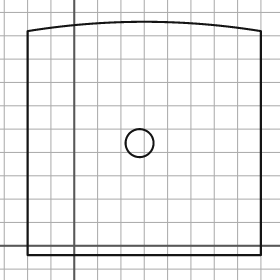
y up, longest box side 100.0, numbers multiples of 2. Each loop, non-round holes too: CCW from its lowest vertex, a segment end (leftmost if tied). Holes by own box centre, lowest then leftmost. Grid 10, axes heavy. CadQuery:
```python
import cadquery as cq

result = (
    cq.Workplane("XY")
    .moveTo(-20.0, -4.0)
    .lineTo(80.0, -4.0)
    .lineTo(80.0, 92.0)
    .threePointArc((30.0, 96.0), (-20.0, 92.0))
    .close()
    .moveTo(28.0, 44.0)
    .circle(6.0)
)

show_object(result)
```